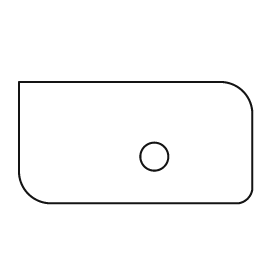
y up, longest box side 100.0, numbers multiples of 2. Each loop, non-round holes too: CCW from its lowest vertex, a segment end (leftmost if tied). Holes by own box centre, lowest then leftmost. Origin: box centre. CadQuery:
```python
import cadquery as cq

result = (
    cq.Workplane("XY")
    .moveTo(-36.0, -26.0)
    .lineTo(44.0, -26.0)
    .threePointArc((48.0, -24.0), (50.0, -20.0))
    .lineTo(50.0, 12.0)
    .threePointArc((46.0, 22.0), (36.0, 26.0))
    .lineTo(-50.0, 26.0)
    .lineTo(-50.0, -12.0)
    .threePointArc((-46.0, -22.0), (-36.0, -26.0))
    .close()
    .moveTo(8.0, -6.0)
    .circle(6.0)
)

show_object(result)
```